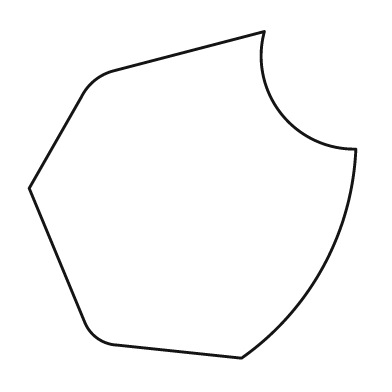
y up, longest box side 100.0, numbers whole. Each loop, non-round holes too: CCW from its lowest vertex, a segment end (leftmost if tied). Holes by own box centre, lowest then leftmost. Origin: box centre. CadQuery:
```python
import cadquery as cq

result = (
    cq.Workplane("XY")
    .moveTo(15.0, -50.0)
    .threePointArc((40.0, -22.0), (50.0, 14.0))
    .threePointArc((27.0, 25.0), (22.0, 50.0))
    .lineTo(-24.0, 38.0)
    .threePointArc((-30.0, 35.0), (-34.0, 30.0))
    .lineTo(-50.0, 2.0)
    .lineTo(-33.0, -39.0)
    .threePointArc((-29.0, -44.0), (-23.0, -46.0))
    .close()
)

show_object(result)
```